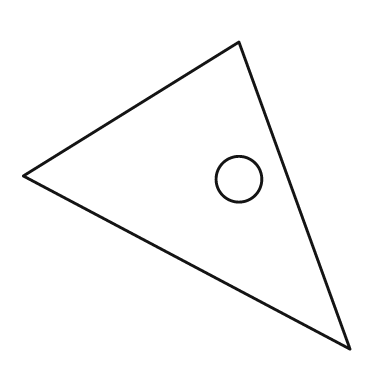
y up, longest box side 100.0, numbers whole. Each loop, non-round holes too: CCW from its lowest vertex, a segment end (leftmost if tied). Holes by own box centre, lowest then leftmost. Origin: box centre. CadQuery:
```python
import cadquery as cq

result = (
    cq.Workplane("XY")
    .moveTo(50.0, -47.0)
    .lineTo(16.0, 47.0)
    .lineTo(-50.0, 6.0)
    .close()
    .moveTo(16.0, 5.0)
    .circle(7.0)
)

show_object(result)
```